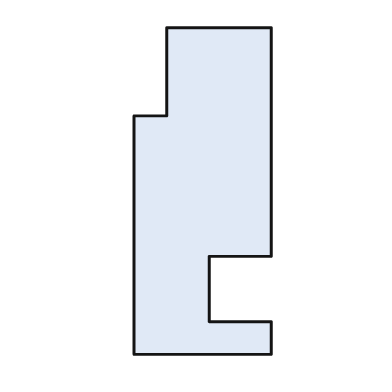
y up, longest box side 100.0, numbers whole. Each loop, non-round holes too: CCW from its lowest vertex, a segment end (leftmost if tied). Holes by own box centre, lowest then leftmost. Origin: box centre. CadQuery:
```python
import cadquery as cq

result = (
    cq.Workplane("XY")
    .moveTo(-21.0, -50.0)
    .lineTo(21.0, -50.0)
    .lineTo(21.0, -40.0)
    .lineTo(2.0, -40.0)
    .lineTo(2.0, -20.0)
    .lineTo(21.0, -20.0)
    .lineTo(21.0, 50.0)
    .lineTo(-11.0, 50.0)
    .lineTo(-11.0, 23.0)
    .lineTo(-21.0, 23.0)
    .close()
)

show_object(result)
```